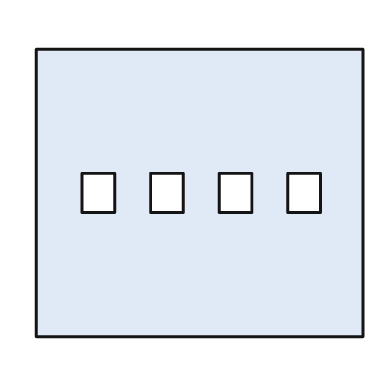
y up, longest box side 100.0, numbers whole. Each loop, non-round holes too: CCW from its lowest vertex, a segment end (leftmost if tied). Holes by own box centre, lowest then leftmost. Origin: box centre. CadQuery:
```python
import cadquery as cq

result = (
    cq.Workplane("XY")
    .moveTo(-50.0, -44.0)
    .lineTo(50.0, -44.0)
    .lineTo(50.0, 44.0)
    .lineTo(-50.0, 44.0)
    .close()
    .moveTo(-36.0, -6.0)
    .lineTo(-26.0, -6.0)
    .lineTo(-26.0, 6.0)
    .lineTo(-36.0, 6.0)
    .close()
    .moveTo(-15.0, -6.0)
    .lineTo(-5.0, -6.0)
    .lineTo(-5.0, 6.0)
    .lineTo(-15.0, 6.0)
    .close()
    .moveTo(6.0, -6.0)
    .lineTo(16.0, -6.0)
    .lineTo(16.0, 6.0)
    .lineTo(6.0, 6.0)
    .close()
    .moveTo(27.0, -6.0)
    .lineTo(37.0, -6.0)
    .lineTo(37.0, 6.0)
    .lineTo(27.0, 6.0)
    .close()
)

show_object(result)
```